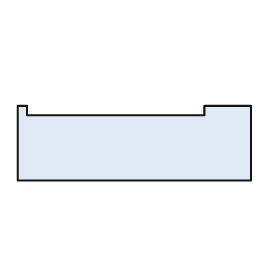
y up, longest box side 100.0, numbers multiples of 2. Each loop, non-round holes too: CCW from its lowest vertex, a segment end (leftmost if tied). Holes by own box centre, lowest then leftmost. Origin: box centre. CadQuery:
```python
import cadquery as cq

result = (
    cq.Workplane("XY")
    .moveTo(-50.0, -16.0)
    .lineTo(50.0, -16.0)
    .lineTo(50.0, 16.0)
    .lineTo(30.0, 16.0)
    .lineTo(30.0, 12.0)
    .lineTo(-46.0, 12.0)
    .lineTo(-46.0, 16.0)
    .lineTo(-50.0, 16.0)
    .close()
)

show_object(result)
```